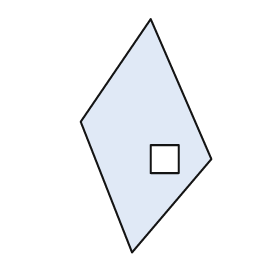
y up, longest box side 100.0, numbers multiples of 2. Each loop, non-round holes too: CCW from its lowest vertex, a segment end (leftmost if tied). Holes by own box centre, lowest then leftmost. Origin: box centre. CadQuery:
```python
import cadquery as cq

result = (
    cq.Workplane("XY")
    .moveTo(-6.0, -50.0)
    .lineTo(28.0, -10.0)
    .lineTo(2.0, 50.0)
    .lineTo(-28.0, 6.0)
    .close()
    .moveTo(2.0, -16.0)
    .lineTo(14.0, -16.0)
    .lineTo(14.0, -4.0)
    .lineTo(2.0, -4.0)
    .close()
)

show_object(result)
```